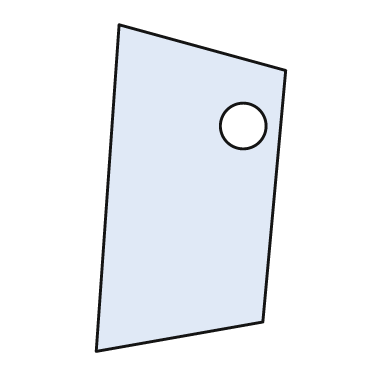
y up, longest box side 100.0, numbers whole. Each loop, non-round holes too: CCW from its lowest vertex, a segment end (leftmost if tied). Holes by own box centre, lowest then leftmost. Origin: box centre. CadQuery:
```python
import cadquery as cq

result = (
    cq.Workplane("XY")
    .moveTo(-29.0, -50.0)
    .lineTo(22.0, -41.0)
    .lineTo(29.0, 36.0)
    .lineTo(-22.0, 50.0)
    .close()
    .moveTo(16.0, 19.0)
    .circle(7.0)
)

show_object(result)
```